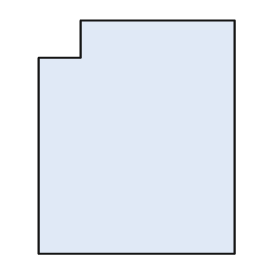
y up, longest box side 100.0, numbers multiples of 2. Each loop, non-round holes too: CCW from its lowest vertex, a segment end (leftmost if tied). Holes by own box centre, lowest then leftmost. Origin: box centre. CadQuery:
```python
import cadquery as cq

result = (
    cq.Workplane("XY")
    .moveTo(-42.0, -50.0)
    .lineTo(42.0, -50.0)
    .lineTo(42.0, 50.0)
    .lineTo(-24.0, 50.0)
    .lineTo(-24.0, 34.0)
    .lineTo(-42.0, 34.0)
    .close()
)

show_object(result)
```